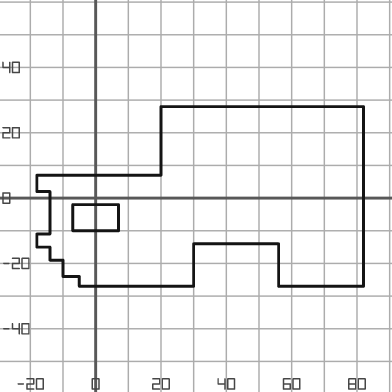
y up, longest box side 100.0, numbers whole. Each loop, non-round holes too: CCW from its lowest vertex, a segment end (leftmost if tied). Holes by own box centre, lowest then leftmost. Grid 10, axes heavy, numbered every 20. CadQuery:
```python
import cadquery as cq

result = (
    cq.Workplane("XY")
    .moveTo(-5.0, -27.0)
    .lineTo(30.0, -27.0)
    .lineTo(30.0, -14.0)
    .lineTo(56.0, -14.0)
    .lineTo(56.0, -27.0)
    .lineTo(82.0, -27.0)
    .lineTo(82.0, 28.0)
    .lineTo(20.0, 28.0)
    .lineTo(20.0, 7.0)
    .lineTo(-18.0, 7.0)
    .lineTo(-18.0, 2.0)
    .lineTo(-14.0, 2.0)
    .lineTo(-14.0, -11.0)
    .lineTo(-18.0, -11.0)
    .lineTo(-18.0, -15.0)
    .lineTo(-14.0, -15.0)
    .lineTo(-14.0, -19.0)
    .lineTo(-10.0, -19.0)
    .lineTo(-10.0, -24.0)
    .lineTo(-5.0, -24.0)
    .close()
    .moveTo(-7.0, -10.0)
    .lineTo(7.0, -10.0)
    .lineTo(7.0, -2.0)
    .lineTo(-7.0, -2.0)
    .close()
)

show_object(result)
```